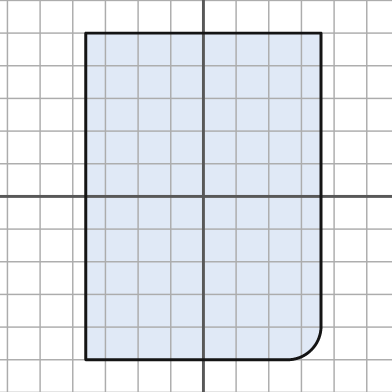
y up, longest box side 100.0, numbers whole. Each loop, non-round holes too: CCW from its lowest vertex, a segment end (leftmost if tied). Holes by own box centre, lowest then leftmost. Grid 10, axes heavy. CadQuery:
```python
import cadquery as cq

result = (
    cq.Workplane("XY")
    .moveTo(-36.0, -50.0)
    .lineTo(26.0, -50.0)
    .threePointArc((33.0, -47.0), (36.0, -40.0))
    .lineTo(36.0, 50.0)
    .lineTo(-36.0, 50.0)
    .close()
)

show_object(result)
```